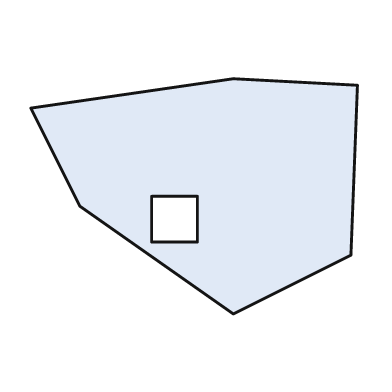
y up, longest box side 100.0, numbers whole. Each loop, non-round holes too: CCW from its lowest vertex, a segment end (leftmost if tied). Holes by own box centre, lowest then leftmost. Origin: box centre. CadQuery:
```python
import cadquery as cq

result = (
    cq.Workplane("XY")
    .moveTo(12.0, -36.0)
    .lineTo(48.0, -18.0)
    .lineTo(50.0, 34.0)
    .lineTo(12.0, 36.0)
    .lineTo(-50.0, 27.0)
    .lineTo(-35.0, -3.0)
    .close()
    .moveTo(-13.0, -14.0)
    .lineTo(1.0, -14.0)
    .lineTo(1.0, 0.0)
    .lineTo(-13.0, 0.0)
    .close()
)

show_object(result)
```